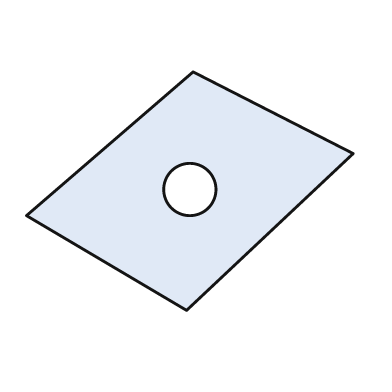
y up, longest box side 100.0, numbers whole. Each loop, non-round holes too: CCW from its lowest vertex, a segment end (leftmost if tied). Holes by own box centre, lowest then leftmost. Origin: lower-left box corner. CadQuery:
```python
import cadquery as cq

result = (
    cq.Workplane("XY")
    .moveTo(49.0, 0.0)
    .lineTo(100.0, 48.0)
    .lineTo(51.0, 73.0)
    .lineTo(0.0, 29.0)
    .close()
    .moveTo(50.0, 37.0)
    .circle(8.0)
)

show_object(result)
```